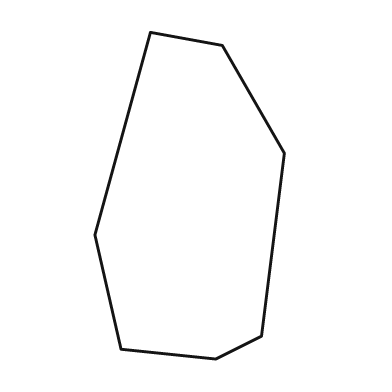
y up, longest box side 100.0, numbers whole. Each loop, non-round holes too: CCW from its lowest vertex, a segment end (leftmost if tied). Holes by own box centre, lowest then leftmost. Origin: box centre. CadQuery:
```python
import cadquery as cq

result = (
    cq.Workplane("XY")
    .moveTo(8.0, -50.0)
    .lineTo(22.0, -43.0)
    .lineTo(29.0, 13.0)
    .lineTo(10.0, 46.0)
    .lineTo(-12.0, 50.0)
    .lineTo(-29.0, -12.0)
    .lineTo(-21.0, -47.0)
    .close()
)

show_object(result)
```